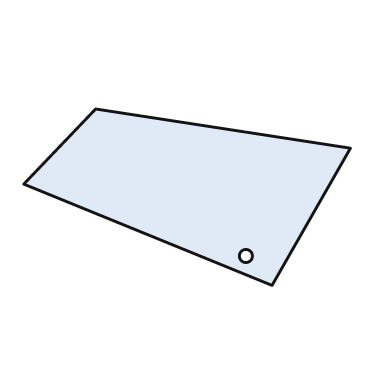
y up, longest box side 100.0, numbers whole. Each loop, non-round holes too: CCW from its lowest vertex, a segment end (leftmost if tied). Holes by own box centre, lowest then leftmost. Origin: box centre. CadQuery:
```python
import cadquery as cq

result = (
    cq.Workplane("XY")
    .moveTo(26.0, -27.0)
    .lineTo(50.0, 15.0)
    .lineTo(-28.0, 27.0)
    .lineTo(-50.0, 4.0)
    .close()
    .moveTo(18.0, -18.0)
    .circle(2.0)
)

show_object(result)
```